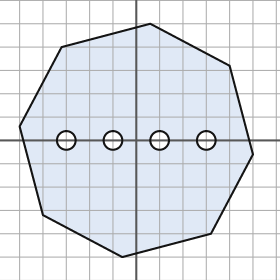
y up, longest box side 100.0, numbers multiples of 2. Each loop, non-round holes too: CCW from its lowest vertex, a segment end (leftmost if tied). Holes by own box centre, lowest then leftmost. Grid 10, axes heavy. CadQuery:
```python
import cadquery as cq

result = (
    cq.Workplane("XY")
    .moveTo(-6.0, -50.0)
    .lineTo(32.0, -40.0)
    .lineTo(50.0, -6.0)
    .lineTo(40.0, 32.0)
    .lineTo(6.0, 50.0)
    .lineTo(-32.0, 40.0)
    .lineTo(-50.0, 6.0)
    .lineTo(-40.0, -32.0)
    .close()
    .moveTo(-30.0, 0.0)
    .circle(4.0)
    .moveTo(-10.0, 0.0)
    .circle(4.0)
    .moveTo(10.0, 0.0)
    .circle(4.0)
    .moveTo(30.0, 0.0)
    .circle(4.0)
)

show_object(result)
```